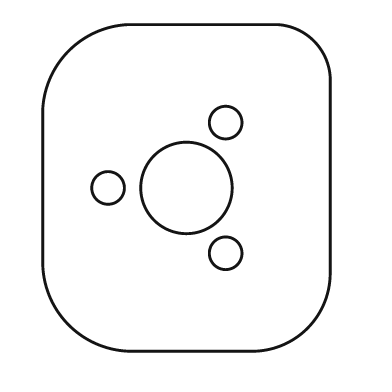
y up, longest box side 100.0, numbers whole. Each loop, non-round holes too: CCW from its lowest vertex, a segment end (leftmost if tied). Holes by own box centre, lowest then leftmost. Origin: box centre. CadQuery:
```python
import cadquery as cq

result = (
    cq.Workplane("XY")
    .moveTo(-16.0, -50.0)
    .lineTo(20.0, -50.0)
    .threePointArc((37.0, -43.0), (44.0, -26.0))
    .lineTo(44.0, 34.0)
    .threePointArc((39.0, 45.0), (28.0, 50.0))
    .lineTo(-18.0, 50.0)
    .threePointArc((-36.0, 42.0), (-44.0, 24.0))
    .lineTo(-44.0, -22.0)
    .threePointArc((-36.0, -42.0), (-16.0, -50.0))
    .close()
    .moveTo(12.0, -20.0)
    .circle(5.0)
    .moveTo(-24.0, 0.0)
    .circle(5.0)
    .moveTo(0.0, 0.0)
    .circle(14.0)
    .moveTo(12.0, 20.0)
    .circle(5.0)
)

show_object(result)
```